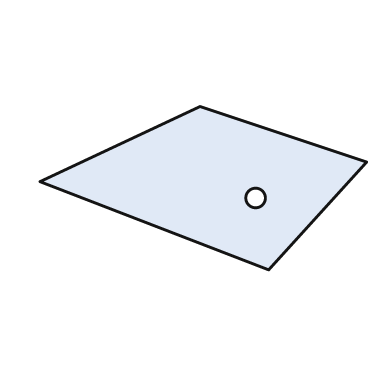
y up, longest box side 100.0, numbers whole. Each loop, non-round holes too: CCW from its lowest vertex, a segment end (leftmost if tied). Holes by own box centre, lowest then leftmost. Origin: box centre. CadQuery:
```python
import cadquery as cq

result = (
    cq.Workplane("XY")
    .moveTo(20.0, -25.0)
    .lineTo(50.0, 8.0)
    .lineTo(-1.0, 25.0)
    .lineTo(-50.0, 2.0)
    .close()
    .moveTo(16.0, -3.0)
    .circle(3.0)
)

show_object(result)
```